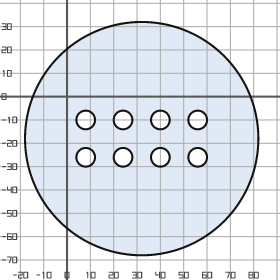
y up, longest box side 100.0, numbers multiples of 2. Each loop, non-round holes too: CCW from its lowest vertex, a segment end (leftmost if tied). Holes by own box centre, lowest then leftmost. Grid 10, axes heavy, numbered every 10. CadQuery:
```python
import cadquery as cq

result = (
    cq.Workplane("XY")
    .moveTo(32.0, -18.0)
    .circle(50.0)
    .moveTo(8.0, -26.0)
    .circle(4.0)
    .moveTo(24.0, -26.0)
    .circle(4.0)
    .moveTo(40.0, -26.0)
    .circle(4.0)
    .moveTo(56.0, -26.0)
    .circle(4.0)
    .moveTo(8.0, -10.0)
    .circle(4.0)
    .moveTo(24.0, -10.0)
    .circle(4.0)
    .moveTo(40.0, -10.0)
    .circle(4.0)
    .moveTo(56.0, -10.0)
    .circle(4.0)
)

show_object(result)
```